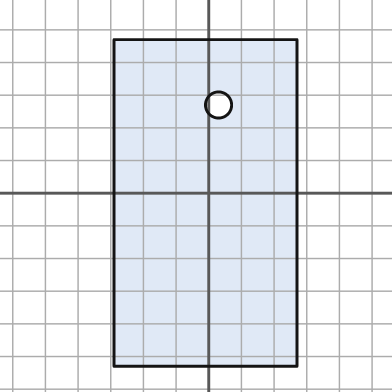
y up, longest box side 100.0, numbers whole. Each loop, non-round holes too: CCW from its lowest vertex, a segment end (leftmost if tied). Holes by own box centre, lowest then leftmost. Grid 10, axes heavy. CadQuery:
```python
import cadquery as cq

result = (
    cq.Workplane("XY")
    .moveTo(-29.0, -53.0)
    .lineTo(27.0, -53.0)
    .lineTo(27.0, 47.0)
    .lineTo(-29.0, 47.0)
    .close()
    .moveTo(3.0, 27.0)
    .circle(4.0)
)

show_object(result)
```